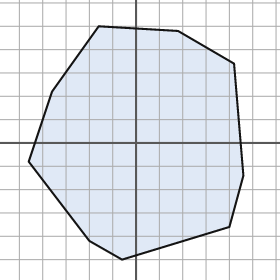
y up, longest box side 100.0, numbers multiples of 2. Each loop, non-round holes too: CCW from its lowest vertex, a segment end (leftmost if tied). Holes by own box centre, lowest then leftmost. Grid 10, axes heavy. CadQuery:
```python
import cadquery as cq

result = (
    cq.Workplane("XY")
    .moveTo(-6.0, -50.0)
    .lineTo(40.0, -36.0)
    .lineTo(46.0, -14.0)
    .lineTo(42.0, 34.0)
    .lineTo(18.0, 48.0)
    .lineTo(-16.0, 50.0)
    .lineTo(-36.0, 22.0)
    .lineTo(-46.0, -8.0)
    .lineTo(-20.0, -42.0)
    .close()
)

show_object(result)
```